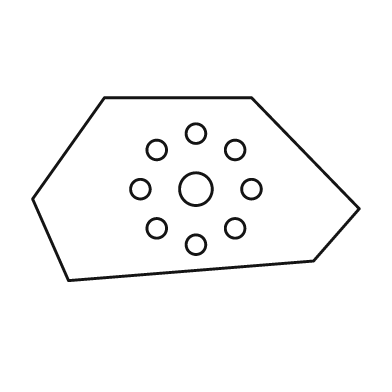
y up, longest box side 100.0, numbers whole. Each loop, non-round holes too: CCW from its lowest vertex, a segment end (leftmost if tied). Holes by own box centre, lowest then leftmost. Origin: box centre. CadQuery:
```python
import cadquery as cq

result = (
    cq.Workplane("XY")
    .moveTo(-39.0, -28.0)
    .lineTo(36.0, -22.0)
    .lineTo(50.0, -6.0)
    .lineTo(17.0, 28.0)
    .lineTo(-28.0, 28.0)
    .lineTo(-50.0, -3.0)
    .close()
    .moveTo(0.0, -17.0)
    .circle(3.0)
    .moveTo(-12.0, -12.0)
    .circle(3.0)
    .moveTo(12.0, -12.0)
    .circle(3.0)
    .moveTo(-17.0, 0.0)
    .circle(3.0)
    .moveTo(0.0, 0.0)
    .circle(5.0)
    .moveTo(17.0, 0.0)
    .circle(3.0)
    .moveTo(-12.0, 12.0)
    .circle(3.0)
    .moveTo(12.0, 12.0)
    .circle(3.0)
    .moveTo(0.0, 17.0)
    .circle(3.0)
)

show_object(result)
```